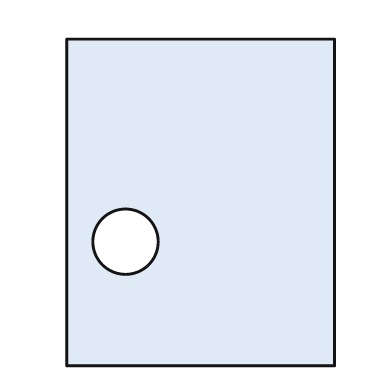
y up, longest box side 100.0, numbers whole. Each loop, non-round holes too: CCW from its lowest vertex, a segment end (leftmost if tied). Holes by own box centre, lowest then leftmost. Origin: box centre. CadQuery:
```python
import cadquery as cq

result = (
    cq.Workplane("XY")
    .moveTo(-41.0, -50.0)
    .lineTo(41.0, -50.0)
    .lineTo(41.0, 50.0)
    .lineTo(-41.0, 50.0)
    .close()
    .moveTo(-23.0, -12.0)
    .circle(10.0)
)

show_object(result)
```